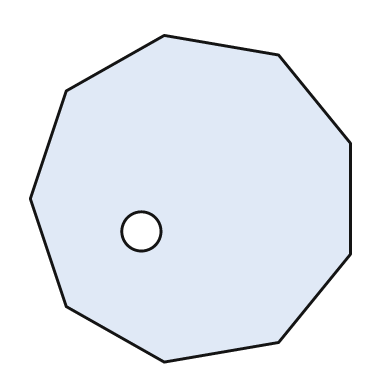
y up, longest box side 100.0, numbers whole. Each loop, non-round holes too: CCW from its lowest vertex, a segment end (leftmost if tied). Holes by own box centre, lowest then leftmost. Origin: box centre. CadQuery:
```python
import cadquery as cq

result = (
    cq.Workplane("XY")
    .moveTo(-8.0, -50.0)
    .lineTo(27.0, -44.0)
    .lineTo(49.0, -17.0)
    .lineTo(49.0, 17.0)
    .lineTo(27.0, 44.0)
    .lineTo(-8.0, 50.0)
    .lineTo(-38.0, 33.0)
    .lineTo(-49.0, 0.0)
    .lineTo(-38.0, -33.0)
    .close()
    .moveTo(-15.0, -10.0)
    .circle(6.0)
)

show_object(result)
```